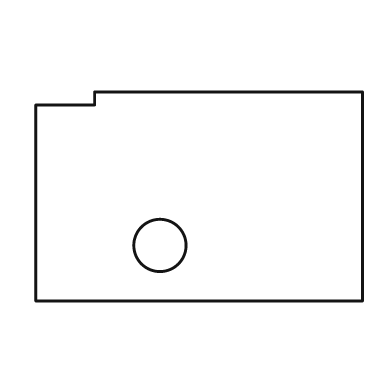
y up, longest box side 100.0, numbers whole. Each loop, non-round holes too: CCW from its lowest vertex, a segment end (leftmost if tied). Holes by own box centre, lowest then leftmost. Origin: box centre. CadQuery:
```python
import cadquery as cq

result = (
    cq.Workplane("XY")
    .moveTo(-50.0, -32.0)
    .lineTo(50.0, -32.0)
    .lineTo(50.0, 32.0)
    .lineTo(-32.0, 32.0)
    .lineTo(-32.0, 28.0)
    .lineTo(-50.0, 28.0)
    .close()
    .moveTo(-12.0, -15.0)
    .circle(8.0)
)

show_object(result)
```